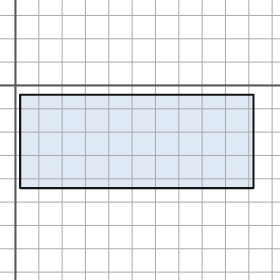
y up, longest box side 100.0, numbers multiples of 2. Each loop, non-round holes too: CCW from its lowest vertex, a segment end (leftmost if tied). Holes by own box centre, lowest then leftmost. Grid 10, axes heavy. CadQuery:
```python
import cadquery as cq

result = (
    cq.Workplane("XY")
    .moveTo(2.0, -44.0)
    .lineTo(102.0, -44.0)
    .lineTo(102.0, -4.0)
    .lineTo(2.0, -4.0)
    .close()
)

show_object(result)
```